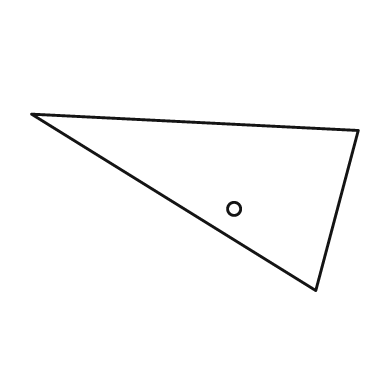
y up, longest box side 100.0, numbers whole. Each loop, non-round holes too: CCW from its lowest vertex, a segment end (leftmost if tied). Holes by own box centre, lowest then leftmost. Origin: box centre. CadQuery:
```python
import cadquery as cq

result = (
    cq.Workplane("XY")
    .moveTo(37.0, -27.0)
    .lineTo(50.0, 22.0)
    .lineTo(-50.0, 27.0)
    .close()
    .moveTo(12.0, -2.0)
    .circle(2.0)
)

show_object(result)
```